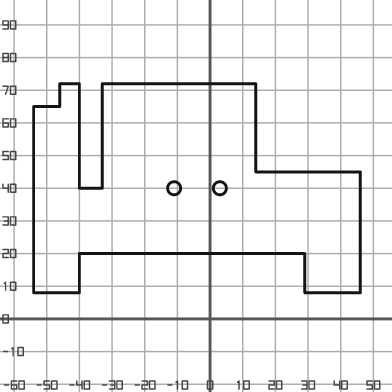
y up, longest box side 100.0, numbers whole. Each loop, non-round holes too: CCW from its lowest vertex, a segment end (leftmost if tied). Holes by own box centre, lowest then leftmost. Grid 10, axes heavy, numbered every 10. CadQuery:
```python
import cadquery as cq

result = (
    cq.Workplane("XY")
    .moveTo(-54.0, 8.0)
    .lineTo(-40.0, 8.0)
    .lineTo(-40.0, 20.0)
    .lineTo(29.0, 20.0)
    .lineTo(29.0, 8.0)
    .lineTo(46.0, 8.0)
    .lineTo(46.0, 45.0)
    .lineTo(14.0, 45.0)
    .lineTo(14.0, 72.0)
    .lineTo(-33.0, 72.0)
    .lineTo(-33.0, 40.0)
    .lineTo(-40.0, 40.0)
    .lineTo(-40.0, 72.0)
    .lineTo(-46.0, 72.0)
    .lineTo(-46.0, 65.0)
    .lineTo(-54.0, 65.0)
    .close()
    .moveTo(-11.0, 40.0)
    .circle(2.0)
    .moveTo(3.0, 40.0)
    .circle(2.0)
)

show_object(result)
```